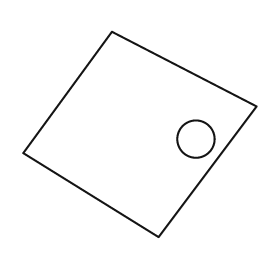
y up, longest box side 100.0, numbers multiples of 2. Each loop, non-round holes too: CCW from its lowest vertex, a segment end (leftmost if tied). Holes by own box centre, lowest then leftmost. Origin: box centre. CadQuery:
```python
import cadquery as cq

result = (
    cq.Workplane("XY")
    .moveTo(8.0, -44.0)
    .lineTo(50.0, 12.0)
    .lineTo(-12.0, 44.0)
    .lineTo(-50.0, -8.0)
    .close()
    .moveTo(24.0, -2.0)
    .circle(8.0)
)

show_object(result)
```